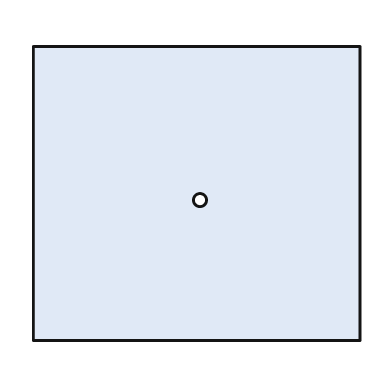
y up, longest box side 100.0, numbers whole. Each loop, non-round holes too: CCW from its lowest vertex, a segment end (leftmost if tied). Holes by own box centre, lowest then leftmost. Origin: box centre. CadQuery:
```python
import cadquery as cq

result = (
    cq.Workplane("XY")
    .moveTo(-50.0, -45.0)
    .lineTo(50.0, -45.0)
    .lineTo(50.0, 45.0)
    .lineTo(-50.0, 45.0)
    .close()
    .moveTo(1.0, -2.0)
    .circle(2.0)
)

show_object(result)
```